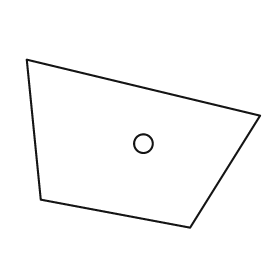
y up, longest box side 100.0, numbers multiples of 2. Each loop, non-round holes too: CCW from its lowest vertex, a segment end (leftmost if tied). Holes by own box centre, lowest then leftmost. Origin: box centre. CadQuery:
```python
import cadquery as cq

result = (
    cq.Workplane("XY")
    .moveTo(20.0, -36.0)
    .lineTo(50.0, 12.0)
    .lineTo(-50.0, 36.0)
    .lineTo(-44.0, -24.0)
    .close()
    .moveTo(0.0, 0.0)
    .circle(4.0)
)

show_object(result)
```